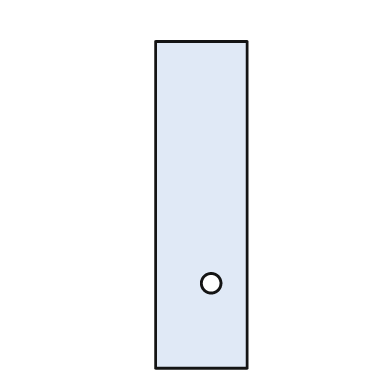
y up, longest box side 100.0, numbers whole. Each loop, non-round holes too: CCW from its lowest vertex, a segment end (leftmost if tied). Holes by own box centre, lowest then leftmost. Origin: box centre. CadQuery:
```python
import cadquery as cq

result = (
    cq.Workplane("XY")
    .moveTo(-14.0, -50.0)
    .lineTo(14.0, -50.0)
    .lineTo(14.0, 50.0)
    .lineTo(-14.0, 50.0)
    .close()
    .moveTo(3.0, -24.0)
    .circle(3.0)
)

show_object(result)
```